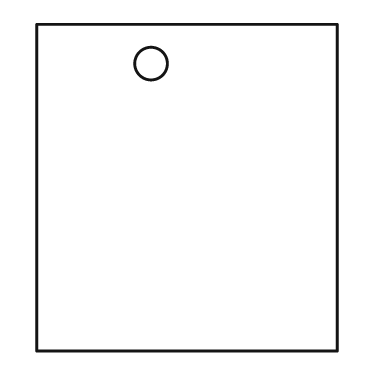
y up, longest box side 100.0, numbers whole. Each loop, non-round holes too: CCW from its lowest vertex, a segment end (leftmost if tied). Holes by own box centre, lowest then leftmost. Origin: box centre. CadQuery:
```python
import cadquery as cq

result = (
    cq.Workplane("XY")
    .moveTo(-46.0, -50.0)
    .lineTo(46.0, -50.0)
    .lineTo(46.0, 50.0)
    .lineTo(-46.0, 50.0)
    .close()
    .moveTo(-11.0, 38.0)
    .circle(5.0)
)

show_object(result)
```